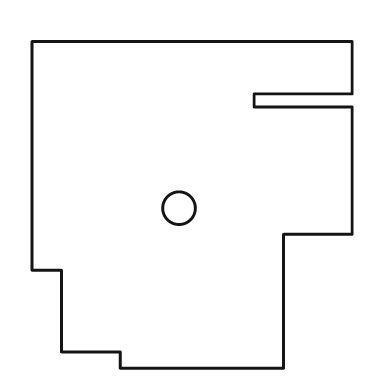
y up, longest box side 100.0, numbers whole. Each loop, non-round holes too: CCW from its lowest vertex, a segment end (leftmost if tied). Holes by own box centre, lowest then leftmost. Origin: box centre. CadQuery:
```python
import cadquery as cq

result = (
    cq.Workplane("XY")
    .moveTo(-22.0, -50.0)
    .lineTo(28.0, -50.0)
    .lineTo(28.0, -9.0)
    .lineTo(49.0, -9.0)
    .lineTo(49.0, 30.0)
    .lineTo(19.0, 30.0)
    .lineTo(19.0, 34.0)
    .lineTo(49.0, 34.0)
    .lineTo(49.0, 50.0)
    .lineTo(-49.0, 50.0)
    .lineTo(-49.0, -20.0)
    .lineTo(-40.0, -20.0)
    .lineTo(-40.0, -45.0)
    .lineTo(-22.0, -45.0)
    .close()
    .moveTo(-4.0, -1.0)
    .circle(5.0)
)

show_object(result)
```